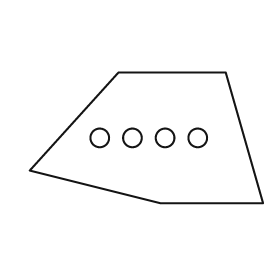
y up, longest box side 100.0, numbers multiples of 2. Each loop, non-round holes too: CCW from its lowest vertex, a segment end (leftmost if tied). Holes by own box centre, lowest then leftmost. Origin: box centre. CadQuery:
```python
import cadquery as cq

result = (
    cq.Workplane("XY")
    .moveTo(6.0, -28.0)
    .lineTo(50.0, -28.0)
    .lineTo(34.0, 28.0)
    .lineTo(-12.0, 28.0)
    .lineTo(-50.0, -14.0)
    .close()
    .moveTo(-20.0, 0.0)
    .circle(4.0)
    .moveTo(-6.0, 0.0)
    .circle(4.0)
    .moveTo(8.0, 0.0)
    .circle(4.0)
    .moveTo(22.0, 0.0)
    .circle(4.0)
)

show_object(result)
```